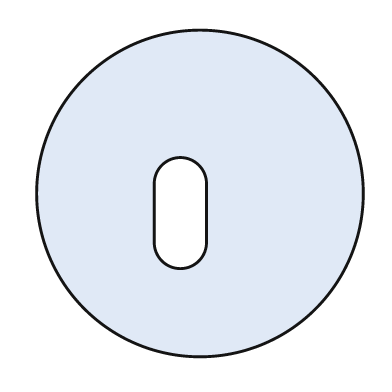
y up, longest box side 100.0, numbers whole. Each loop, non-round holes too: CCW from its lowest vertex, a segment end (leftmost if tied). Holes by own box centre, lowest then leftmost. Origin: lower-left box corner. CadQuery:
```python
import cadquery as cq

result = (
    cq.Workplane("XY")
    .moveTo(50.0, 50.0)
    .circle(50.0)
    .moveTo(36.0, 35.0)
    .threePointArc((44.0, 27.0), (52.0, 35.0))
    .lineTo(52.0, 53.0)
    .threePointArc((44.0, 61.0), (36.0, 53.0))
    .close()
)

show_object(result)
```